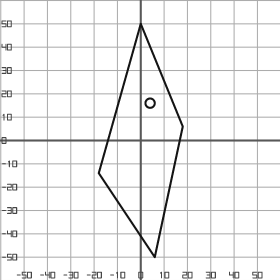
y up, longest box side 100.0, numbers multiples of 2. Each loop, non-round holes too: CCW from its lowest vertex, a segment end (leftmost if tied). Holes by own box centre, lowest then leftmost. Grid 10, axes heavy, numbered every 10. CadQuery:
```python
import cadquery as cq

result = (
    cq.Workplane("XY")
    .moveTo(6.0, -50.0)
    .lineTo(18.0, 6.0)
    .lineTo(0.0, 50.0)
    .lineTo(-18.0, -14.0)
    .close()
    .moveTo(4.0, 16.0)
    .circle(2.0)
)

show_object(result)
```